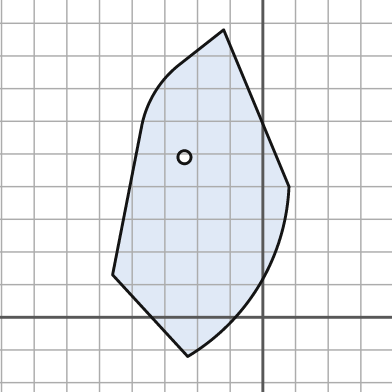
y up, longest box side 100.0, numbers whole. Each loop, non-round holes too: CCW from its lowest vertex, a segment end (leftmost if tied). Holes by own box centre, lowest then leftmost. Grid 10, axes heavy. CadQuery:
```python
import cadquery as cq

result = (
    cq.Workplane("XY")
    .moveTo(-23.0, -12.0)
    .threePointArc((-1.0, 10.0), (8.0, 40.0))
    .lineTo(-12.0, 88.0)
    .lineTo(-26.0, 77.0)
    .threePointArc((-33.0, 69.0), (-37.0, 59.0))
    .lineTo(-46.0, 13.0)
    .close()
    .moveTo(-24.0, 49.0)
    .circle(2.0)
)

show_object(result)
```